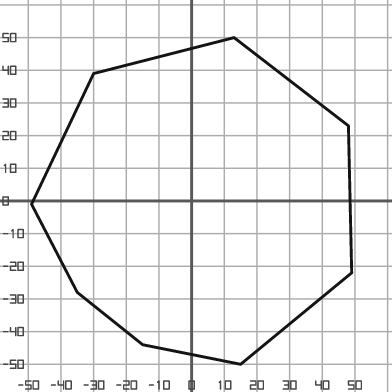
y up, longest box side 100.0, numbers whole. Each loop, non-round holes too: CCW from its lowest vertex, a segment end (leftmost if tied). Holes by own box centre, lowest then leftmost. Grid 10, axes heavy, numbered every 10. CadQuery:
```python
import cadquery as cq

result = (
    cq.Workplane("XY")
    .moveTo(15.0, -50.0)
    .lineTo(49.0, -22.0)
    .lineTo(48.0, 23.0)
    .lineTo(13.0, 50.0)
    .lineTo(-30.0, 39.0)
    .lineTo(-49.0, -1.0)
    .lineTo(-35.0, -28.0)
    .lineTo(-15.0, -44.0)
    .close()
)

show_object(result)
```